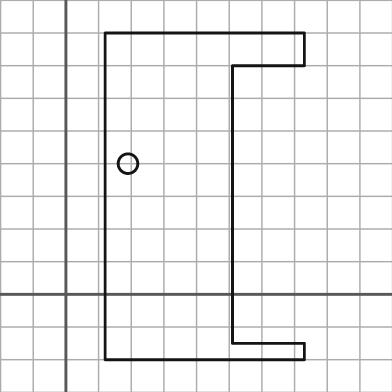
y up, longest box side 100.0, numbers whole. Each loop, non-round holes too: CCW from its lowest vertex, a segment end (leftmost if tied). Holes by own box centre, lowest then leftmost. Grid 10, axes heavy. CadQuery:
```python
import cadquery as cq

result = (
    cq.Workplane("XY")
    .moveTo(12.0, -20.0)
    .lineTo(73.0, -20.0)
    .lineTo(73.0, -15.0)
    .lineTo(51.0, -15.0)
    .lineTo(51.0, 70.0)
    .lineTo(73.0, 70.0)
    .lineTo(73.0, 80.0)
    .lineTo(12.0, 80.0)
    .close()
    .moveTo(19.0, 40.0)
    .circle(3.0)
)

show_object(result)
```